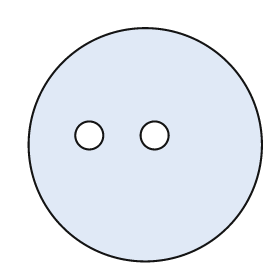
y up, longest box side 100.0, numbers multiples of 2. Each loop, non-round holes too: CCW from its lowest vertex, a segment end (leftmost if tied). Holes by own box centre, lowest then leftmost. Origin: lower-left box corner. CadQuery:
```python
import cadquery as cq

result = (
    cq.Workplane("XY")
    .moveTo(50.0, 50.0)
    .circle(50.0)
    .moveTo(26.0, 54.0)
    .circle(6.0)
    .moveTo(54.0, 54.0)
    .circle(6.0)
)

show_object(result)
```